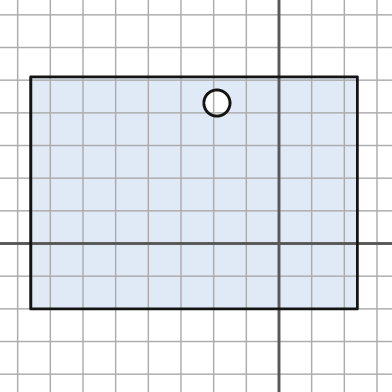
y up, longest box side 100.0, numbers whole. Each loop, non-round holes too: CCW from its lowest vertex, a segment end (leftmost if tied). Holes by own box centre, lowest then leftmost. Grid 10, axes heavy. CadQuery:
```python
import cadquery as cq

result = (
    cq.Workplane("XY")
    .moveTo(-76.0, -20.0)
    .lineTo(24.0, -20.0)
    .lineTo(24.0, 51.0)
    .lineTo(-76.0, 51.0)
    .close()
    .moveTo(-19.0, 43.0)
    .circle(4.0)
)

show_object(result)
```